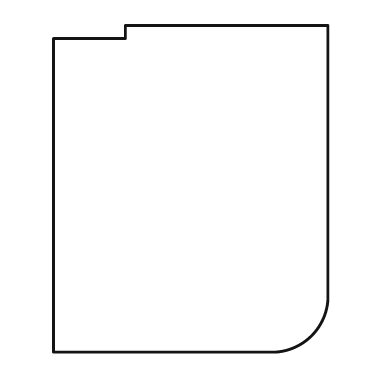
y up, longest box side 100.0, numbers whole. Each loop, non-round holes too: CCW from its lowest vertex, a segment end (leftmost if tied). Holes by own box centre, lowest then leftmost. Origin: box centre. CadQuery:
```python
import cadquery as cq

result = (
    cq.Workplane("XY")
    .moveTo(-42.0, -50.0)
    .lineTo(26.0, -50.0)
    .threePointArc((37.0, -45.0), (42.0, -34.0))
    .lineTo(42.0, 50.0)
    .lineTo(-20.0, 50.0)
    .lineTo(-20.0, 46.0)
    .lineTo(-42.0, 46.0)
    .close()
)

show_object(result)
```